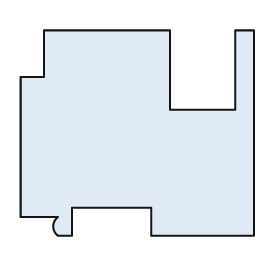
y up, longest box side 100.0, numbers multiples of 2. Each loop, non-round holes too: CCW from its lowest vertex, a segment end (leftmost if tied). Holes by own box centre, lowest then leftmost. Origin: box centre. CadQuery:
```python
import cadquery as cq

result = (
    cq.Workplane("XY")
    .moveTo(-34.0, -44.0)
    .lineTo(-28.0, -44.0)
    .lineTo(-28.0, -32.0)
    .lineTo(6.0, -32.0)
    .lineTo(6.0, -44.0)
    .lineTo(50.0, -44.0)
    .lineTo(50.0, 44.0)
    .lineTo(42.0, 44.0)
    .lineTo(42.0, 10.0)
    .lineTo(14.0, 10.0)
    .lineTo(14.0, 44.0)
    .lineTo(-40.0, 44.0)
    .lineTo(-40.0, 24.0)
    .lineTo(-50.0, 24.0)
    .lineTo(-50.0, -36.0)
    .lineTo(-34.0, -36.0)
    .threePointArc((-36.0, -40.0), (-34.0, -44.0))
    .close()
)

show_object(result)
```